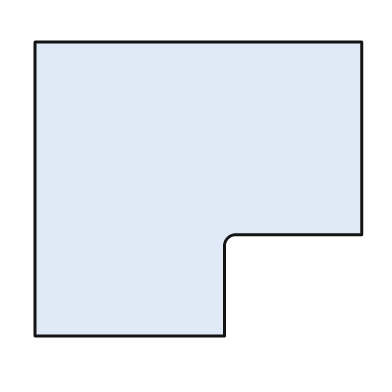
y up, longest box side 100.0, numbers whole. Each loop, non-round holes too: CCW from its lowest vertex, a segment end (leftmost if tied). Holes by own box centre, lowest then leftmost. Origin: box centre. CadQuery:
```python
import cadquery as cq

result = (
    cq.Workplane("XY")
    .moveTo(-50.0, -45.0)
    .lineTo(8.0, -45.0)
    .lineTo(8.0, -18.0)
    .threePointArc((9.0, -15.0), (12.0, -14.0))
    .lineTo(50.0, -14.0)
    .lineTo(50.0, 45.0)
    .lineTo(-50.0, 45.0)
    .close()
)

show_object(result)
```